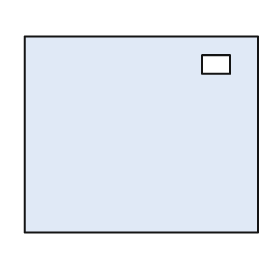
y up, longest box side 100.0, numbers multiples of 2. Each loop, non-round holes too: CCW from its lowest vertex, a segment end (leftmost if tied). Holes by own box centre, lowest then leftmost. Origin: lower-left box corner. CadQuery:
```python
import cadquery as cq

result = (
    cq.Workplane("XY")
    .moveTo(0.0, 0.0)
    .lineTo(100.0, 0.0)
    .lineTo(100.0, 84.0)
    .lineTo(0.0, 84.0)
    .close()
    .moveTo(76.0, 68.0)
    .lineTo(88.0, 68.0)
    .lineTo(88.0, 76.0)
    .lineTo(76.0, 76.0)
    .close()
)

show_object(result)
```